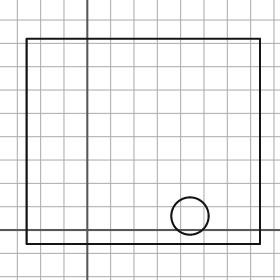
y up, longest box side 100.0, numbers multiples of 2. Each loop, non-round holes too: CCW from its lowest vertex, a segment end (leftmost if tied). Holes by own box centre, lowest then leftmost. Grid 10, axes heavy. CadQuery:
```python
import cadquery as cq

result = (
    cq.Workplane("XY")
    .moveTo(-26.0, -6.0)
    .lineTo(74.0, -6.0)
    .lineTo(74.0, 82.0)
    .lineTo(-26.0, 82.0)
    .close()
    .moveTo(44.0, 6.0)
    .circle(8.0)
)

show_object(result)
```